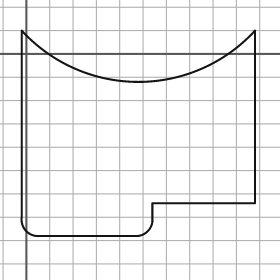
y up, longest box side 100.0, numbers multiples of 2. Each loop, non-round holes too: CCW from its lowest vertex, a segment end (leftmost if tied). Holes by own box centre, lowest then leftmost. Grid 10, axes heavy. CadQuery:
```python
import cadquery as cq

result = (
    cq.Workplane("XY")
    .moveTo(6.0, -78.0)
    .lineTo(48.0, -78.0)
    .threePointArc((52.0, -76.0), (54.0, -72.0))
    .lineTo(54.0, -64.0)
    .lineTo(98.0, -64.0)
    .lineTo(98.0, 10.0)
    .threePointArc((48.0, -12.0), (-2.0, 10.0))
    .lineTo(-2.0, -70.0)
    .threePointArc((0.0, -76.0), (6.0, -78.0))
    .close()
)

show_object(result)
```